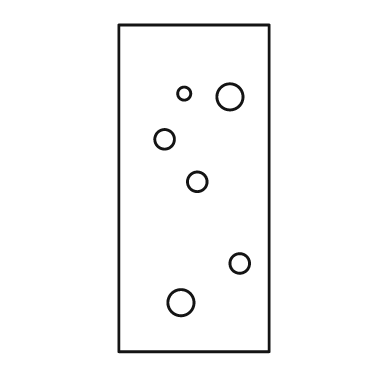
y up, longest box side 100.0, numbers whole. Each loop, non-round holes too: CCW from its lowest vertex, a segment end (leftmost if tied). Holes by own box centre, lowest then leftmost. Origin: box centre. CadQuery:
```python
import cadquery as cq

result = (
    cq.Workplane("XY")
    .moveTo(-23.0, -50.0)
    .lineTo(23.0, -50.0)
    .lineTo(23.0, 50.0)
    .lineTo(-23.0, 50.0)
    .close()
    .moveTo(-4.0, -35.0)
    .circle(4.0)
    .moveTo(14.0, -23.0)
    .circle(3.0)
    .moveTo(1.0, 2.0)
    .circle(3.0)
    .moveTo(-9.0, 15.0)
    .circle(3.0)
    .moveTo(11.0, 28.0)
    .circle(4.0)
    .moveTo(-3.0, 29.0)
    .circle(2.0)
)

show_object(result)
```